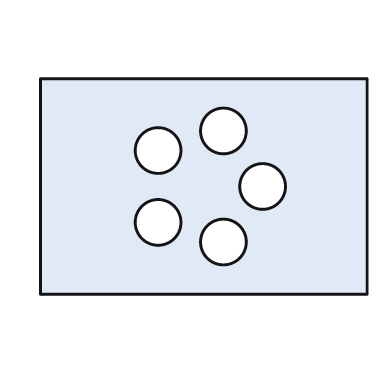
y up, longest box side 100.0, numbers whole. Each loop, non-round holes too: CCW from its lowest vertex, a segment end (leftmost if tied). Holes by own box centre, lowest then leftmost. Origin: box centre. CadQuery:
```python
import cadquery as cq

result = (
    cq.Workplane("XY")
    .moveTo(-50.0, -33.0)
    .lineTo(50.0, -33.0)
    .lineTo(50.0, 33.0)
    .lineTo(-50.0, 33.0)
    .close()
    .moveTo(6.0, -17.0)
    .circle(7.0)
    .moveTo(-14.0, -11.0)
    .circle(7.0)
    .moveTo(18.0, 0.0)
    .circle(7.0)
    .moveTo(-14.0, 11.0)
    .circle(7.0)
    .moveTo(6.0, 17.0)
    .circle(7.0)
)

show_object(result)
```